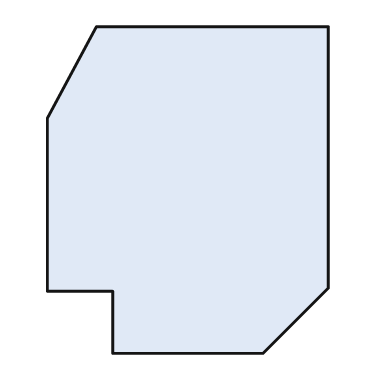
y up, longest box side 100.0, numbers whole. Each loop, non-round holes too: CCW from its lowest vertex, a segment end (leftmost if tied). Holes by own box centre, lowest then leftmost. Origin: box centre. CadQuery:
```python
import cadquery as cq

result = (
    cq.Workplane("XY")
    .moveTo(-23.0, -50.0)
    .lineTo(23.0, -50.0)
    .lineTo(43.0, -30.0)
    .lineTo(43.0, 50.0)
    .lineTo(-28.0, 50.0)
    .lineTo(-43.0, 22.0)
    .lineTo(-43.0, -31.0)
    .lineTo(-23.0, -31.0)
    .close()
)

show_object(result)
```